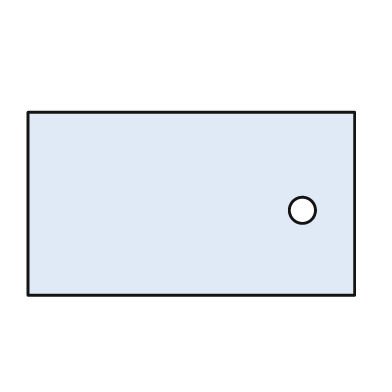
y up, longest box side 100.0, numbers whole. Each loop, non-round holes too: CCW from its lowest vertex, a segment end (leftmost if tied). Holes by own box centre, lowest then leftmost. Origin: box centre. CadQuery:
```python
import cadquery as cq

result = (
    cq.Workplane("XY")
    .moveTo(-50.0, -28.0)
    .lineTo(50.0, -28.0)
    .lineTo(50.0, 28.0)
    .lineTo(-50.0, 28.0)
    .close()
    .moveTo(34.0, -2.0)
    .circle(4.0)
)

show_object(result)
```